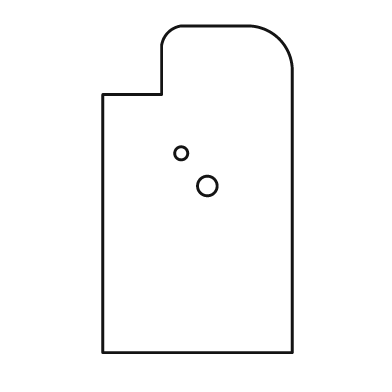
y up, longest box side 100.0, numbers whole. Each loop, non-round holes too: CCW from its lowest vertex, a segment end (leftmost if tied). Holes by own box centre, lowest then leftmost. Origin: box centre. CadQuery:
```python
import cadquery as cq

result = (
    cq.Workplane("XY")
    .moveTo(-29.0, -50.0)
    .lineTo(29.0, -50.0)
    .lineTo(29.0, 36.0)
    .threePointArc((25.0, 46.0), (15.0, 50.0))
    .lineTo(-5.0, 50.0)
    .threePointArc((-9.0, 48.0), (-11.0, 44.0))
    .lineTo(-11.0, 29.0)
    .lineTo(-29.0, 29.0)
    .close()
    .moveTo(3.0, 1.0)
    .circle(3.0)
    .moveTo(-5.0, 11.0)
    .circle(2.0)
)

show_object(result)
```